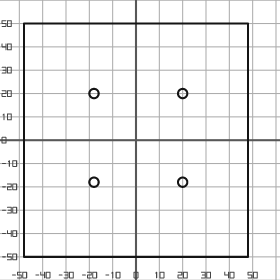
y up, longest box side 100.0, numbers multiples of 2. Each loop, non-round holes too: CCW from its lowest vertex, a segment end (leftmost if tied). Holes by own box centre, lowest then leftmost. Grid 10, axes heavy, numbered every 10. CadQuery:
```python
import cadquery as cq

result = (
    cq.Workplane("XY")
    .moveTo(-48.0, -50.0)
    .lineTo(48.0, -50.0)
    .lineTo(48.0, 50.0)
    .lineTo(-48.0, 50.0)
    .close()
    .moveTo(-18.0, -18.0)
    .circle(2.0)
    .moveTo(20.0, -18.0)
    .circle(2.0)
    .moveTo(-18.0, 20.0)
    .circle(2.0)
    .moveTo(20.0, 20.0)
    .circle(2.0)
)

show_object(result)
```